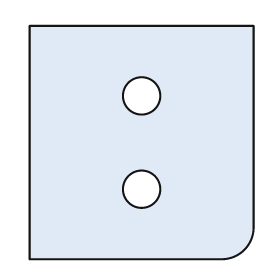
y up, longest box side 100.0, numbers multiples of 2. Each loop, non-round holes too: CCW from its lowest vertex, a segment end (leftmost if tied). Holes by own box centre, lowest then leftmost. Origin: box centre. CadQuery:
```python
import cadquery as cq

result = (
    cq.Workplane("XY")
    .moveTo(-48.0, -50.0)
    .lineTo(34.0, -50.0)
    .threePointArc((44.0, -46.0), (48.0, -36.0))
    .lineTo(48.0, 50.0)
    .lineTo(-48.0, 50.0)
    .close()
    .moveTo(0.0, -20.0)
    .circle(8.0)
    .moveTo(0.0, 20.0)
    .circle(8.0)
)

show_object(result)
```